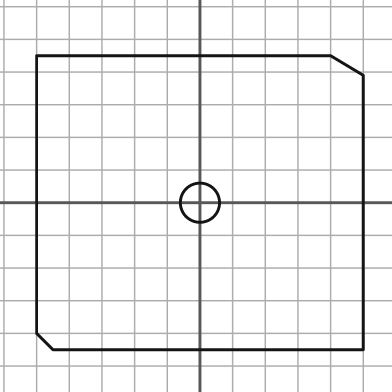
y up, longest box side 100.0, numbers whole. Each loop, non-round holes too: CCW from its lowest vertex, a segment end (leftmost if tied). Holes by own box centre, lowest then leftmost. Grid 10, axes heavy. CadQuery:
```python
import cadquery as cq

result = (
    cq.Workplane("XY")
    .moveTo(-45.0, -45.0)
    .lineTo(50.0, -45.0)
    .lineTo(50.0, 39.0)
    .lineTo(40.0, 45.0)
    .lineTo(-50.0, 45.0)
    .lineTo(-50.0, -40.0)
    .close()
    .moveTo(0.0, 0.0)
    .circle(6.0)
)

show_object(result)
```